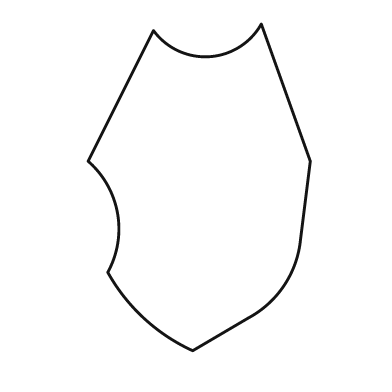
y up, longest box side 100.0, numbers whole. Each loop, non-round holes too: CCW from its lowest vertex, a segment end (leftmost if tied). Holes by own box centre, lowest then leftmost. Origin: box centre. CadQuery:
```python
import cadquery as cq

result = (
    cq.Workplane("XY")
    .moveTo(-2.0, -50.0)
    .lineTo(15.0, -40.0)
    .threePointArc((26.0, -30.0), (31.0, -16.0))
    .lineTo(34.0, 8.0)
    .lineTo(19.0, 50.0)
    .threePointArc((3.0, 40.0), (-14.0, 48.0))
    .lineTo(-34.0, 8.0)
    .threePointArc((-25.0, -8.0), (-28.0, -26.0))
    .threePointArc((-17.0, -40.0), (-2.0, -50.0))
    .close()
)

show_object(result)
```